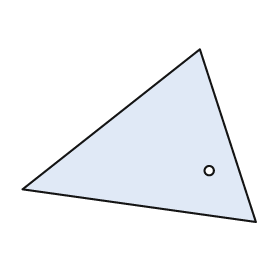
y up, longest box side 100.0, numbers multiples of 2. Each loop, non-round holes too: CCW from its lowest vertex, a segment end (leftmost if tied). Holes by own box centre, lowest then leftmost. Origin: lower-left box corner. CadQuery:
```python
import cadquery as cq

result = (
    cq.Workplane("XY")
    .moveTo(100.0, 0.0)
    .lineTo(76.0, 74.0)
    .lineTo(0.0, 14.0)
    .close()
    .moveTo(80.0, 22.0)
    .circle(2.0)
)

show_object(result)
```